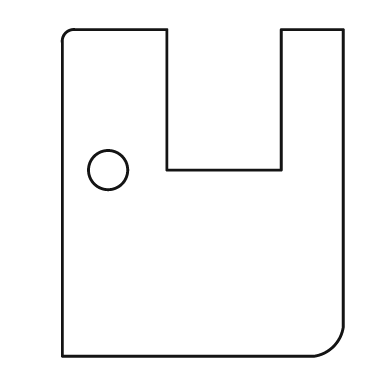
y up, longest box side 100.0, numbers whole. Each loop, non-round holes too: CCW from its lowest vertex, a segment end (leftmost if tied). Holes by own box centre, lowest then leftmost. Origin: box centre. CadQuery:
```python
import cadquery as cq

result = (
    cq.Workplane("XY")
    .moveTo(-43.0, -50.0)
    .lineTo(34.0, -50.0)
    .threePointArc((40.0, -47.0), (43.0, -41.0))
    .lineTo(43.0, 50.0)
    .lineTo(24.0, 50.0)
    .lineTo(24.0, 7.0)
    .lineTo(-11.0, 7.0)
    .lineTo(-11.0, 50.0)
    .lineTo(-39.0, 50.0)
    .threePointArc((-42.0, 49.0), (-43.0, 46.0))
    .close()
    .moveTo(-29.0, 7.0)
    .circle(6.0)
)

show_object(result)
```